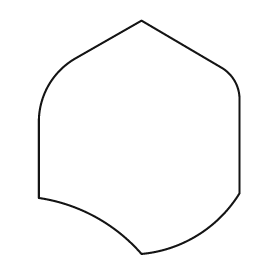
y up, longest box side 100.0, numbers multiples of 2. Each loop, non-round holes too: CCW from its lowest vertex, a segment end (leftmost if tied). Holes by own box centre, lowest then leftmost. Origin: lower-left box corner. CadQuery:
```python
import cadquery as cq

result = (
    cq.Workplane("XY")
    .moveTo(44.0, 0.0)
    .threePointArc((68.0, 8.0), (86.0, 26.0))
    .lineTo(86.0, 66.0)
    .threePointArc((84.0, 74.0), (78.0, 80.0))
    .lineTo(44.0, 100.0)
    .lineTo(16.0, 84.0)
    .threePointArc((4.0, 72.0), (0.0, 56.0))
    .lineTo(0.0, 24.0)
    .threePointArc((24.0, 16.0), (44.0, 0.0))
    .close()
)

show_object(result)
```